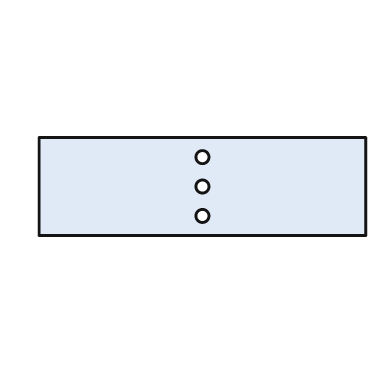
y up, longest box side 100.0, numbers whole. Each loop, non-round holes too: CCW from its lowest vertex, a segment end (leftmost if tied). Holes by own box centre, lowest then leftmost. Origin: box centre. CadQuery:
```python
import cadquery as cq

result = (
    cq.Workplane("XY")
    .moveTo(-50.0, -15.0)
    .lineTo(50.0, -15.0)
    .lineTo(50.0, 15.0)
    .lineTo(-50.0, 15.0)
    .close()
    .moveTo(0.0, -9.0)
    .circle(2.0)
    .moveTo(0.0, 0.0)
    .circle(2.0)
    .moveTo(0.0, 9.0)
    .circle(2.0)
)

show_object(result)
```